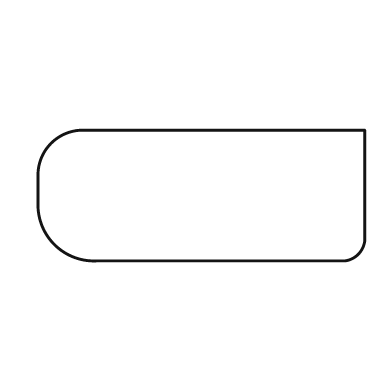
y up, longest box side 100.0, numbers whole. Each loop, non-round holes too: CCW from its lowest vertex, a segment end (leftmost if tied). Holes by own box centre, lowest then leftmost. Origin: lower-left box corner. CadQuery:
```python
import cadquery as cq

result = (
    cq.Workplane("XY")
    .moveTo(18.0, 0.0)
    .lineTo(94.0, 0.0)
    .threePointArc((98.0, 2.0), (100.0, 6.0))
    .lineTo(100.0, 40.0)
    .lineTo(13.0, 40.0)
    .threePointArc((4.0, 36.0), (0.0, 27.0))
    .lineTo(0.0, 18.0)
    .threePointArc((5.0, 5.0), (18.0, 0.0))
    .close()
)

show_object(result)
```